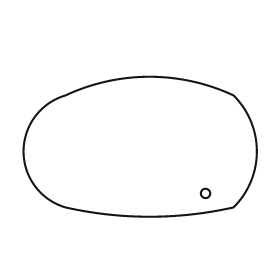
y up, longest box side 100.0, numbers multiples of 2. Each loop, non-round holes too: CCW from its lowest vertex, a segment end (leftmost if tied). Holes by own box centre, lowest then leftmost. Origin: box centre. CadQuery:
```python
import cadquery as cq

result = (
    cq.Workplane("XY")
    .moveTo(-32.0, -26.0)
    .threePointArc((4.0, -30.0), (40.0, -26.0))
    .threePointArc((50.0, -2.0), (40.0, 22.0))
    .threePointArc((4.0, 30.0), (-32.0, 22.0))
    .threePointArc((-50.0, -2.0), (-32.0, -26.0))
    .close()
    .moveTo(28.0, -20.0)
    .circle(2.0)
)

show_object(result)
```